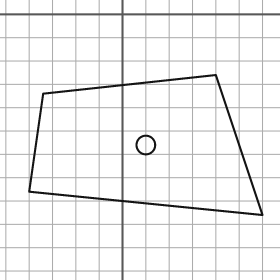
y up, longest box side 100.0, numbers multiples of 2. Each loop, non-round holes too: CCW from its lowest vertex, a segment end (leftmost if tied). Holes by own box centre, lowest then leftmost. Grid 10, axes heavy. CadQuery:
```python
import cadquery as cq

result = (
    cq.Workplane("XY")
    .moveTo(60.0, -86.0)
    .lineTo(40.0, -26.0)
    .lineTo(-34.0, -34.0)
    .lineTo(-40.0, -76.0)
    .close()
    .moveTo(10.0, -56.0)
    .circle(4.0)
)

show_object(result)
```